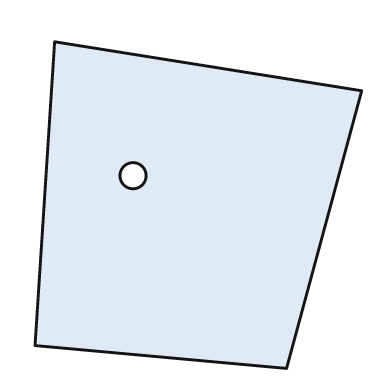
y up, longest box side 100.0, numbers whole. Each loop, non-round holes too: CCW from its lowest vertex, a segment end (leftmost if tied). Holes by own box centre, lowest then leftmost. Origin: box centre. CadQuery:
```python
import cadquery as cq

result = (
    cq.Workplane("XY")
    .moveTo(27.0, -50.0)
    .lineTo(50.0, 35.0)
    .lineTo(-44.0, 50.0)
    .lineTo(-50.0, -43.0)
    .close()
    .moveTo(-20.0, 9.0)
    .circle(4.0)
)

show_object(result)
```